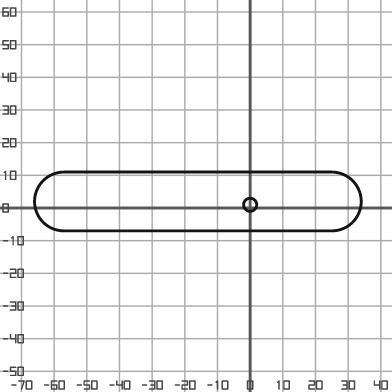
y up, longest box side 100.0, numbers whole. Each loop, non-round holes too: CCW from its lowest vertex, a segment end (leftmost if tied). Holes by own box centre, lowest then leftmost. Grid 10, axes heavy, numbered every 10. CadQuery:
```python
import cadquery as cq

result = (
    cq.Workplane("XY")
    .moveTo(-57.0, -7.0)
    .lineTo(25.0, -7.0)
    .threePointArc((34.0, 2.0), (25.0, 11.0))
    .lineTo(-57.0, 11.0)
    .threePointArc((-66.0, 2.0), (-57.0, -7.0))
    .close()
    .moveTo(0.0, 1.0)
    .circle(2.0)
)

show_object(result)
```